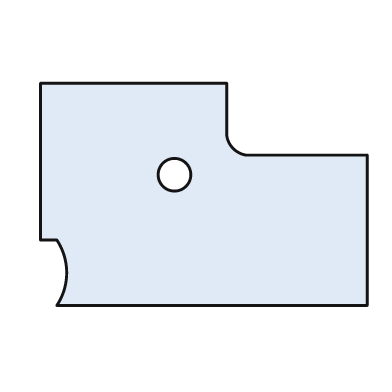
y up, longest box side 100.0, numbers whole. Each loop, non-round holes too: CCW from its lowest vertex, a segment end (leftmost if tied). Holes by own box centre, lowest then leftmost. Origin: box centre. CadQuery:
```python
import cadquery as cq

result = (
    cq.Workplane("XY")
    .moveTo(-45.0, -34.0)
    .lineTo(50.0, -34.0)
    .lineTo(50.0, 12.0)
    .lineTo(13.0, 12.0)
    .threePointArc((9.0, 14.0), (7.0, 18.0))
    .lineTo(7.0, 34.0)
    .lineTo(-50.0, 34.0)
    .lineTo(-50.0, -14.0)
    .lineTo(-45.0, -14.0)
    .threePointArc((-42.0, -24.0), (-45.0, -34.0))
    .close()
    .moveTo(-9.0, 6.0)
    .circle(5.0)
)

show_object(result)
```